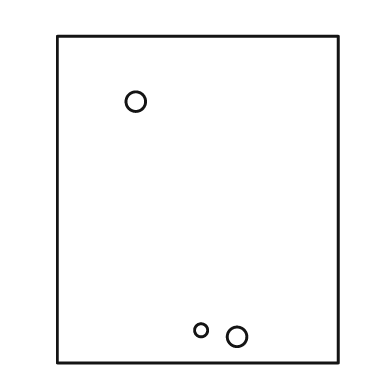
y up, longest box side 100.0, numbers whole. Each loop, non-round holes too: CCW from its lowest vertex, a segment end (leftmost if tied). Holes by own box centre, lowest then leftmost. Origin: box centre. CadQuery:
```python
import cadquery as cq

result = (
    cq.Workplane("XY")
    .moveTo(-43.0, -50.0)
    .lineTo(43.0, -50.0)
    .lineTo(43.0, 50.0)
    .lineTo(-43.0, 50.0)
    .close()
    .moveTo(12.0, -42.0)
    .circle(3.0)
    .moveTo(1.0, -40.0)
    .circle(2.0)
    .moveTo(-19.0, 30.0)
    .circle(3.0)
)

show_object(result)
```